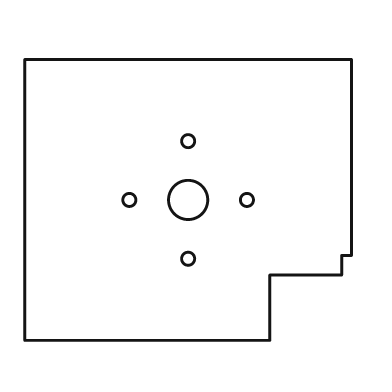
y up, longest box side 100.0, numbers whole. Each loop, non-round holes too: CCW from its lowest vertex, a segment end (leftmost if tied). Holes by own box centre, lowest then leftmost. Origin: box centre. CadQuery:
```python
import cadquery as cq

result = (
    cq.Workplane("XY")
    .moveTo(-50.0, -43.0)
    .lineTo(25.0, -43.0)
    .lineTo(25.0, -23.0)
    .lineTo(47.0, -23.0)
    .lineTo(47.0, -17.0)
    .lineTo(50.0, -17.0)
    .lineTo(50.0, 43.0)
    .lineTo(-50.0, 43.0)
    .close()
    .moveTo(0.0, -18.0)
    .circle(2.0)
    .moveTo(-18.0, 0.0)
    .circle(2.0)
    .moveTo(0.0, 0.0)
    .circle(6.0)
    .moveTo(18.0, 0.0)
    .circle(2.0)
    .moveTo(0.0, 18.0)
    .circle(2.0)
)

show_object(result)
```